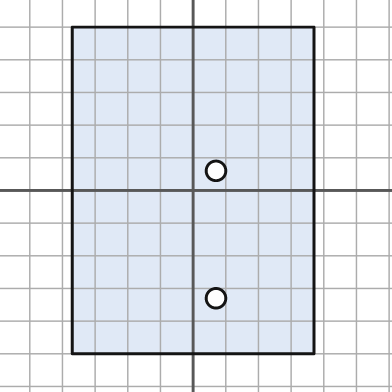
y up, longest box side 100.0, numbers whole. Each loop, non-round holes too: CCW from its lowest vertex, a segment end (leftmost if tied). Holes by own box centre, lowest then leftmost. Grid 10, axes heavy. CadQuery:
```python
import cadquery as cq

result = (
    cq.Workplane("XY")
    .moveTo(-37.0, -50.0)
    .lineTo(37.0, -50.0)
    .lineTo(37.0, 50.0)
    .lineTo(-37.0, 50.0)
    .close()
    .moveTo(7.0, -33.0)
    .circle(3.0)
    .moveTo(7.0, 6.0)
    .circle(3.0)
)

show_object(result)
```